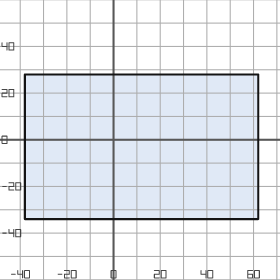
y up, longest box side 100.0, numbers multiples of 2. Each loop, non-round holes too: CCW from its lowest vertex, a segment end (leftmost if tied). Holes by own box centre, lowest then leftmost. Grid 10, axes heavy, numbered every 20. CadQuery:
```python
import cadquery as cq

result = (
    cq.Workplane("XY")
    .moveTo(-38.0, -34.0)
    .lineTo(62.0, -34.0)
    .lineTo(62.0, 28.0)
    .lineTo(-38.0, 28.0)
    .close()
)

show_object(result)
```